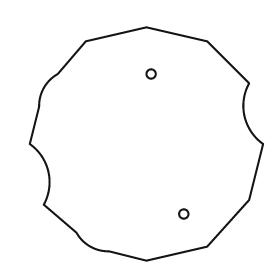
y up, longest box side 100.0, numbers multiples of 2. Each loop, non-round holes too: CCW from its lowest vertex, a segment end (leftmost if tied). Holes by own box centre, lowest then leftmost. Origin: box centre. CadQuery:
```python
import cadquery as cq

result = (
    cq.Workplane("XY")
    .moveTo(0.0, -50.0)
    .lineTo(26.0, -44.0)
    .lineTo(44.0, -24.0)
    .lineTo(50.0, 0.0)
    .threePointArc((42.0, 12.0), (44.0, 26.0))
    .lineTo(26.0, 44.0)
    .lineTo(0.0, 50.0)
    .lineTo(-26.0, 44.0)
    .lineTo(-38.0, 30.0)
    .threePointArc((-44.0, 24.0), (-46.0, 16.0))
    .lineTo(-50.0, 0.0)
    .threePointArc((-42.0, -12.0), (-44.0, -26.0))
    .lineTo(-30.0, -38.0)
    .threePointArc((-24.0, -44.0), (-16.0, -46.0))
    .close()
    .moveTo(16.0, -30.0)
    .circle(2.0)
    .moveTo(2.0, 30.0)
    .circle(2.0)
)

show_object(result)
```